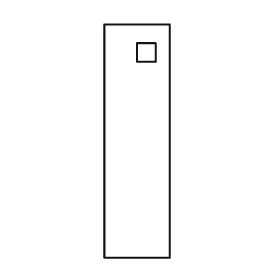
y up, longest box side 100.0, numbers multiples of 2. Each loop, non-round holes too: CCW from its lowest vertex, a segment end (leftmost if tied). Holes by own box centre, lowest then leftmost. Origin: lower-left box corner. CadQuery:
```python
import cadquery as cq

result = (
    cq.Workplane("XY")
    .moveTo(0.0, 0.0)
    .lineTo(28.0, 0.0)
    .lineTo(28.0, 100.0)
    .lineTo(0.0, 100.0)
    .close()
    .moveTo(14.0, 84.0)
    .lineTo(22.0, 84.0)
    .lineTo(22.0, 92.0)
    .lineTo(14.0, 92.0)
    .close()
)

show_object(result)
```